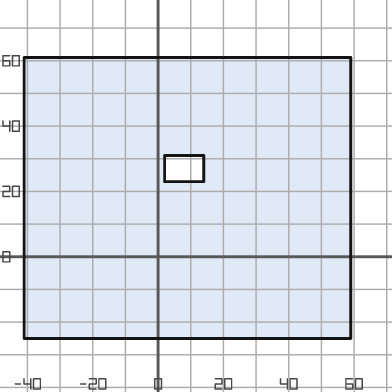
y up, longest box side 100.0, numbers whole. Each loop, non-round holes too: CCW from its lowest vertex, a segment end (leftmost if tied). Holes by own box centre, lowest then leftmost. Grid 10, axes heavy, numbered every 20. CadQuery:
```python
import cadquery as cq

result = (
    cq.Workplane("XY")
    .moveTo(-41.0, -25.0)
    .lineTo(59.0, -25.0)
    .lineTo(59.0, 61.0)
    .lineTo(-41.0, 61.0)
    .close()
    .moveTo(2.0, 23.0)
    .lineTo(14.0, 23.0)
    .lineTo(14.0, 31.0)
    .lineTo(2.0, 31.0)
    .close()
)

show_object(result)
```